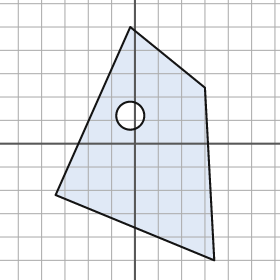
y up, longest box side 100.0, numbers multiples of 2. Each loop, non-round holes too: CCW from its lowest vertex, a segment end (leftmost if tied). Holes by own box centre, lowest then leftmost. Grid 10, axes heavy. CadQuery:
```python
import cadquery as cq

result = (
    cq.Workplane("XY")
    .moveTo(34.0, -50.0)
    .lineTo(30.0, 24.0)
    .lineTo(-2.0, 50.0)
    .lineTo(-34.0, -22.0)
    .close()
    .moveTo(-2.0, 12.0)
    .circle(6.0)
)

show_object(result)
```